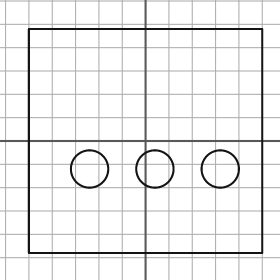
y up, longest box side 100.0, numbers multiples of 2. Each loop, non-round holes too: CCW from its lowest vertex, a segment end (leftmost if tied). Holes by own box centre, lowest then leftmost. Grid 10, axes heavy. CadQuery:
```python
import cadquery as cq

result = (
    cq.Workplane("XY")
    .moveTo(-50.0, -48.0)
    .lineTo(50.0, -48.0)
    .lineTo(50.0, 48.0)
    .lineTo(-50.0, 48.0)
    .close()
    .moveTo(-24.0, -12.0)
    .circle(8.0)
    .moveTo(4.0, -12.0)
    .circle(8.0)
    .moveTo(32.0, -12.0)
    .circle(8.0)
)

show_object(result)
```